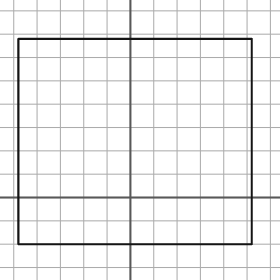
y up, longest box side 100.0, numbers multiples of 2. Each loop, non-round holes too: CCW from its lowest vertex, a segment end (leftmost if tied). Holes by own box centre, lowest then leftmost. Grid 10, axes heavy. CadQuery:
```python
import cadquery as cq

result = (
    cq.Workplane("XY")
    .moveTo(-48.0, -20.0)
    .lineTo(52.0, -20.0)
    .lineTo(52.0, 68.0)
    .lineTo(-48.0, 68.0)
    .close()
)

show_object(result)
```